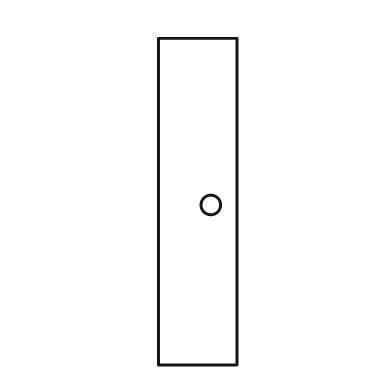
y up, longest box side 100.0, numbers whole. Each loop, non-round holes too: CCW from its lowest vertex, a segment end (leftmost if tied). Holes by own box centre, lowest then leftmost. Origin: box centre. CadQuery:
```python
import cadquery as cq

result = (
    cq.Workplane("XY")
    .moveTo(-12.0, -50.0)
    .lineTo(12.0, -50.0)
    .lineTo(12.0, 50.0)
    .lineTo(-12.0, 50.0)
    .close()
    .moveTo(4.0, -1.0)
    .circle(3.0)
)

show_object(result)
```